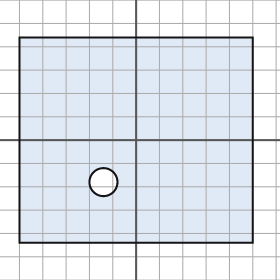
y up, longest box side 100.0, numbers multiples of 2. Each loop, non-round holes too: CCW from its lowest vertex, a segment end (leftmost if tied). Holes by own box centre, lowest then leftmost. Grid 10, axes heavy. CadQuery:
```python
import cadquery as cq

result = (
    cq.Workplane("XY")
    .moveTo(-50.0, -44.0)
    .lineTo(50.0, -44.0)
    .lineTo(50.0, 44.0)
    .lineTo(-50.0, 44.0)
    .close()
    .moveTo(-14.0, -18.0)
    .circle(6.0)
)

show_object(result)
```